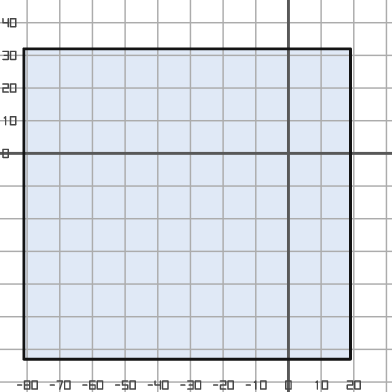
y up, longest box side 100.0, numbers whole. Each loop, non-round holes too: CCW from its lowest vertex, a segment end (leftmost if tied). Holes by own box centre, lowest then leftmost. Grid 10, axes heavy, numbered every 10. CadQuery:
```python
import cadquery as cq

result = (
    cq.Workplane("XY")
    .moveTo(-81.0, -63.0)
    .lineTo(19.0, -63.0)
    .lineTo(19.0, 32.0)
    .lineTo(-81.0, 32.0)
    .close()
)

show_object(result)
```